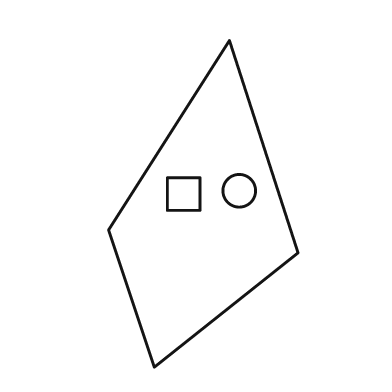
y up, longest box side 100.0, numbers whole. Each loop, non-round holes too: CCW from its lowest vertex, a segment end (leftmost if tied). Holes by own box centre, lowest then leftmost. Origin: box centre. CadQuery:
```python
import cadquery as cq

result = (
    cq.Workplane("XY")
    .moveTo(-15.0, -50.0)
    .lineTo(29.0, -15.0)
    .lineTo(8.0, 50.0)
    .lineTo(-29.0, -8.0)
    .close()
    .moveTo(-11.0, -2.0)
    .lineTo(-1.0, -2.0)
    .lineTo(-1.0, 8.0)
    .lineTo(-11.0, 8.0)
    .close()
    .moveTo(11.0, 4.0)
    .circle(5.0)
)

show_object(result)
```